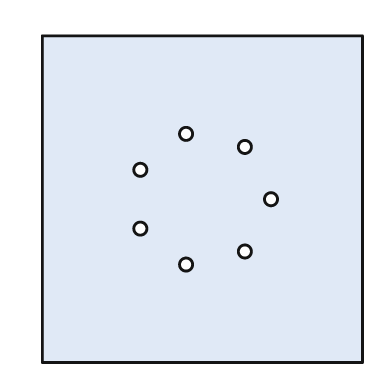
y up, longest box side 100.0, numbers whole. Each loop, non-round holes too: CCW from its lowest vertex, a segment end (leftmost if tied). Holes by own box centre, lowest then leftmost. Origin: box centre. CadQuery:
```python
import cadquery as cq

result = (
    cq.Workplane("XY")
    .moveTo(-49.0, -50.0)
    .lineTo(49.0, -50.0)
    .lineTo(49.0, 50.0)
    .lineTo(-49.0, 50.0)
    .close()
    .moveTo(-5.0, -20.0)
    .circle(2.0)
    .moveTo(13.0, -16.0)
    .circle(2.0)
    .moveTo(-19.0, -9.0)
    .circle(2.0)
    .moveTo(21.0, 0.0)
    .circle(2.0)
    .moveTo(-19.0, 9.0)
    .circle(2.0)
    .moveTo(13.0, 16.0)
    .circle(2.0)
    .moveTo(-5.0, 20.0)
    .circle(2.0)
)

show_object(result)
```